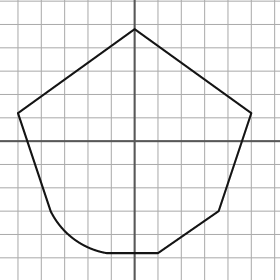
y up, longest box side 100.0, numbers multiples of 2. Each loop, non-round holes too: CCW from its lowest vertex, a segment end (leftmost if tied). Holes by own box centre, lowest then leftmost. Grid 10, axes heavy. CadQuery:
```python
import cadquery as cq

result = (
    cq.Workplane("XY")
    .moveTo(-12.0, -48.0)
    .lineTo(10.0, -48.0)
    .lineTo(36.0, -30.0)
    .lineTo(50.0, 12.0)
    .lineTo(0.0, 48.0)
    .lineTo(-50.0, 12.0)
    .lineTo(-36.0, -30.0)
    .threePointArc((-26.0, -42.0), (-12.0, -48.0))
    .close()
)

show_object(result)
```